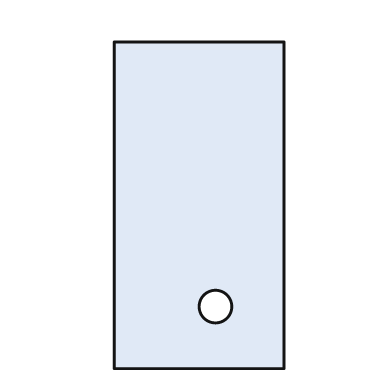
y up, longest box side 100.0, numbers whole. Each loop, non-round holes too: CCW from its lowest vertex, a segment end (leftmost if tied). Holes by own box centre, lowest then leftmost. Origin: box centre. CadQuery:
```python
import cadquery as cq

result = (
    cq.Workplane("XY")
    .moveTo(-26.0, -50.0)
    .lineTo(26.0, -50.0)
    .lineTo(26.0, 50.0)
    .lineTo(-26.0, 50.0)
    .close()
    .moveTo(5.0, -31.0)
    .circle(5.0)
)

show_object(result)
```